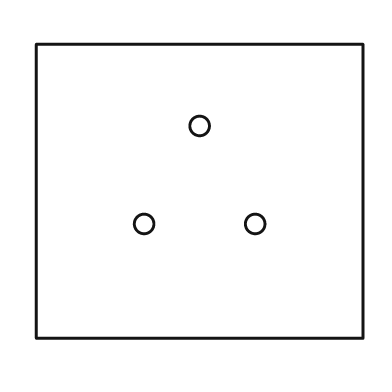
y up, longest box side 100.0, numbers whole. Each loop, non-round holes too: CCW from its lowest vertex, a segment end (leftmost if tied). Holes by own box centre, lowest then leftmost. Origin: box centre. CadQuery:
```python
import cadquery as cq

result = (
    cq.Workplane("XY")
    .moveTo(-50.0, -45.0)
    .lineTo(50.0, -45.0)
    .lineTo(50.0, 45.0)
    .lineTo(-50.0, 45.0)
    .close()
    .moveTo(-17.0, -10.0)
    .circle(3.0)
    .moveTo(17.0, -10.0)
    .circle(3.0)
    .moveTo(0.0, 20.0)
    .circle(3.0)
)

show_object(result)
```